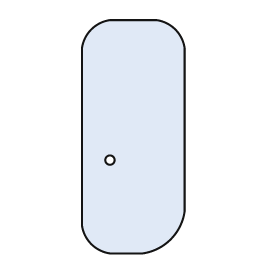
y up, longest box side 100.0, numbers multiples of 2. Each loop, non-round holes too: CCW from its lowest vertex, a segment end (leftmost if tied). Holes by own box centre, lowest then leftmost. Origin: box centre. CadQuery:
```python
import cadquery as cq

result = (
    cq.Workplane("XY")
    .moveTo(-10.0, -50.0)
    .lineTo(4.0, -50.0)
    .threePointArc((16.0, -44.0), (22.0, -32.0))
    .lineTo(22.0, 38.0)
    .threePointArc((18.0, 46.0), (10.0, 50.0))
    .lineTo(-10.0, 50.0)
    .threePointArc((-18.0, 46.0), (-22.0, 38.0))
    .lineTo(-22.0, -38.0)
    .threePointArc((-18.0, -46.0), (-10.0, -50.0))
    .close()
    .moveTo(-10.0, -10.0)
    .circle(2.0)
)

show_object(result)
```